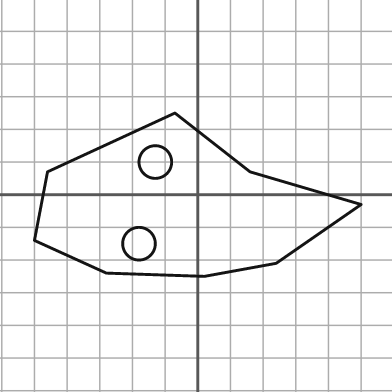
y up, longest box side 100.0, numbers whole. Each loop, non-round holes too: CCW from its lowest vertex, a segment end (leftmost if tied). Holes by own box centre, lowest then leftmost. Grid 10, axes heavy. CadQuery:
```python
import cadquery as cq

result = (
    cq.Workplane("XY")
    .moveTo(2.0, -25.0)
    .lineTo(24.0, -21.0)
    .lineTo(50.0, -3.0)
    .lineTo(16.0, 7.0)
    .lineTo(-7.0, 25.0)
    .lineTo(-46.0, 7.0)
    .lineTo(-50.0, -14.0)
    .lineTo(-28.0, -24.0)
    .close()
    .moveTo(-18.0, -15.0)
    .circle(5.0)
    .moveTo(-13.0, 10.0)
    .circle(5.0)
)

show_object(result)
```